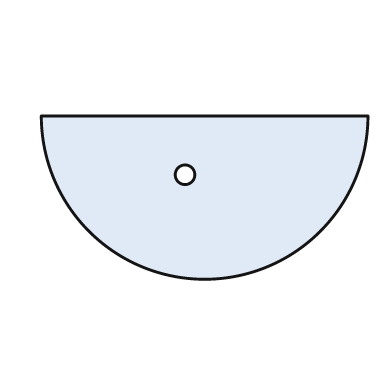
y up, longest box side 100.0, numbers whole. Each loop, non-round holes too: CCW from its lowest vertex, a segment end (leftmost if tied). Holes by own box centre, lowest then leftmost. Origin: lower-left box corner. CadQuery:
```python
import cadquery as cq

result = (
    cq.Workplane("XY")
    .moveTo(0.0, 50.0)
    .threePointArc((50.0, 0.0), (100.0, 50.0))
    .close()
    .moveTo(44.0, 32.0)
    .circle(3.0)
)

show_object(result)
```